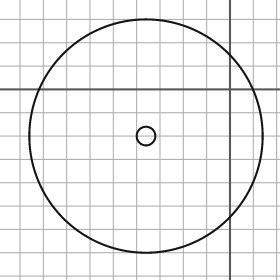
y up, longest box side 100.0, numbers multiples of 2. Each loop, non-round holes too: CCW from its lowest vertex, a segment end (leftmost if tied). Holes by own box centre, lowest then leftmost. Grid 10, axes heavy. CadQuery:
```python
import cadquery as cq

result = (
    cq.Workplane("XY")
    .moveTo(-36.0, -20.0)
    .circle(50.0)
    .moveTo(-36.0, -20.0)
    .circle(4.0)
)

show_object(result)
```